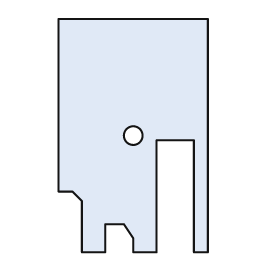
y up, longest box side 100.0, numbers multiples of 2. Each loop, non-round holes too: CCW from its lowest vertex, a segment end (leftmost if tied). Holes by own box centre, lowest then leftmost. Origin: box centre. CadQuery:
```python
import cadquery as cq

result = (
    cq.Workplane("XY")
    .moveTo(-22.0, -50.0)
    .lineTo(-12.0, -50.0)
    .lineTo(-12.0, -38.0)
    .lineTo(-4.0, -38.0)
    .lineTo(0.0, -44.0)
    .lineTo(0.0, -50.0)
    .lineTo(10.0, -50.0)
    .lineTo(10.0, -2.0)
    .lineTo(26.0, -2.0)
    .lineTo(26.0, -50.0)
    .lineTo(32.0, -50.0)
    .lineTo(32.0, 50.0)
    .lineTo(-32.0, 50.0)
    .lineTo(-32.0, -24.0)
    .lineTo(-26.0, -24.0)
    .lineTo(-22.0, -28.0)
    .close()
    .moveTo(0.0, 0.0)
    .circle(4.0)
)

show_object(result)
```